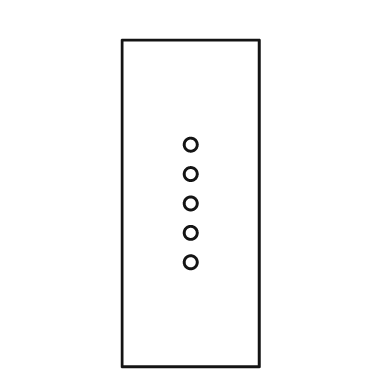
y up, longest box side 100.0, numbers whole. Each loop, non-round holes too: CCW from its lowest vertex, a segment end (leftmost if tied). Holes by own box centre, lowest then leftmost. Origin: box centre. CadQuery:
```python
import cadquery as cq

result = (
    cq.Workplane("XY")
    .moveTo(-21.0, -50.0)
    .lineTo(21.0, -50.0)
    .lineTo(21.0, 50.0)
    .lineTo(-21.0, 50.0)
    .close()
    .moveTo(0.0, -18.0)
    .circle(2.0)
    .moveTo(0.0, -9.0)
    .circle(2.0)
    .moveTo(0.0, 0.0)
    .circle(2.0)
    .moveTo(0.0, 9.0)
    .circle(2.0)
    .moveTo(0.0, 18.0)
    .circle(2.0)
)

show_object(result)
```